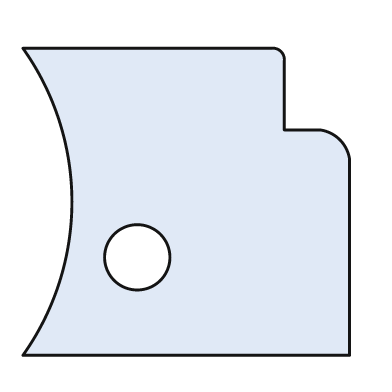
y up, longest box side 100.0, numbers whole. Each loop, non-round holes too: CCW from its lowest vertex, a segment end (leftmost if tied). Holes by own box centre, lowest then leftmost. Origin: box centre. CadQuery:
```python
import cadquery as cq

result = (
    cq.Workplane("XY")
    .moveTo(-50.0, -47.0)
    .lineTo(50.0, -47.0)
    .lineTo(50.0, 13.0)
    .threePointArc((47.0, 19.0), (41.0, 22.0))
    .lineTo(30.0, 22.0)
    .lineTo(30.0, 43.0)
    .threePointArc((29.0, 46.0), (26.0, 47.0))
    .lineTo(-50.0, 47.0)
    .threePointArc((-35.0, 0.0), (-50.0, -47.0))
    .close()
    .moveTo(-15.0, -17.0)
    .circle(10.0)
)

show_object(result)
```